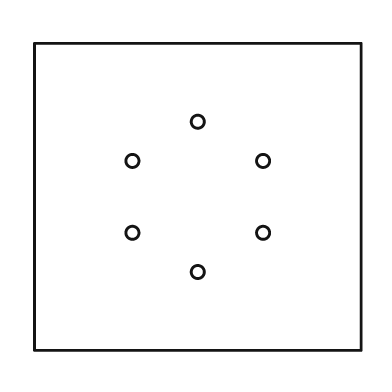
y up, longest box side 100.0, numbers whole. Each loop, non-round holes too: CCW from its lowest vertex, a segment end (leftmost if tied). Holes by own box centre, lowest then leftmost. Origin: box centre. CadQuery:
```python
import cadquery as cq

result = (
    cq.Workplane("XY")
    .moveTo(-50.0, -47.0)
    .lineTo(50.0, -47.0)
    .lineTo(50.0, 47.0)
    .lineTo(-50.0, 47.0)
    .close()
    .moveTo(0.0, -23.0)
    .circle(2.0)
    .moveTo(-20.0, -11.0)
    .circle(2.0)
    .moveTo(20.0, -11.0)
    .circle(2.0)
    .moveTo(-20.0, 11.0)
    .circle(2.0)
    .moveTo(20.0, 11.0)
    .circle(2.0)
    .moveTo(0.0, 23.0)
    .circle(2.0)
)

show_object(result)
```